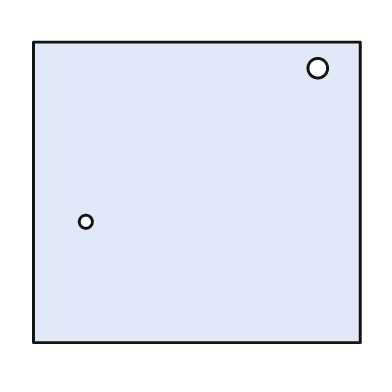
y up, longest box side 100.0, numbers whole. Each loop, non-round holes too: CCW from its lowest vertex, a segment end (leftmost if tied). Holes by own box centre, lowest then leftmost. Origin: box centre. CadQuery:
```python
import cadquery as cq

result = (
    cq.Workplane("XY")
    .moveTo(-50.0, -46.0)
    .lineTo(50.0, -46.0)
    .lineTo(50.0, 46.0)
    .lineTo(-50.0, 46.0)
    .close()
    .moveTo(-34.0, -9.0)
    .circle(2.0)
    .moveTo(37.0, 38.0)
    .circle(3.0)
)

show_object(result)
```